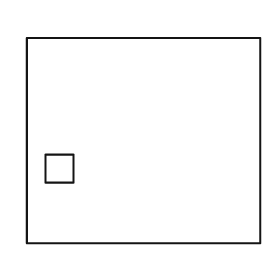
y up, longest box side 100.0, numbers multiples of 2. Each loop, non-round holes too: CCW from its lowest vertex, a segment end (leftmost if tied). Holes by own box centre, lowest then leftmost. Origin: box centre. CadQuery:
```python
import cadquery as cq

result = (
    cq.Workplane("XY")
    .moveTo(-50.0, -44.0)
    .lineTo(50.0, -44.0)
    .lineTo(50.0, 44.0)
    .lineTo(-50.0, 44.0)
    .close()
    .moveTo(-42.0, -18.0)
    .lineTo(-30.0, -18.0)
    .lineTo(-30.0, -6.0)
    .lineTo(-42.0, -6.0)
    .close()
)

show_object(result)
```